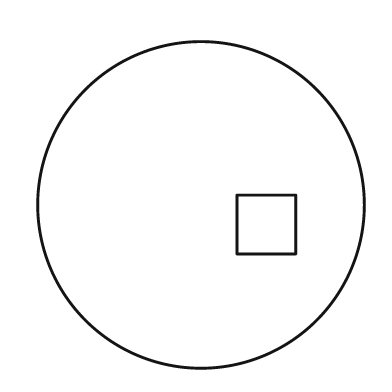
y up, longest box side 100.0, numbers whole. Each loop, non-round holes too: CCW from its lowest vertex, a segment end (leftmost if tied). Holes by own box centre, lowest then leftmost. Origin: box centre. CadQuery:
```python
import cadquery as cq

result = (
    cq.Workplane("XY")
    .moveTo(0.0, 0.0)
    .circle(50.0)
    .moveTo(11.0, -15.0)
    .lineTo(29.0, -15.0)
    .lineTo(29.0, 3.0)
    .lineTo(11.0, 3.0)
    .close()
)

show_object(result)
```